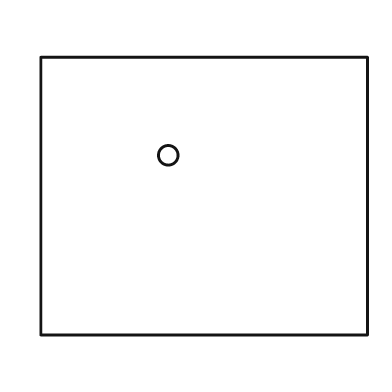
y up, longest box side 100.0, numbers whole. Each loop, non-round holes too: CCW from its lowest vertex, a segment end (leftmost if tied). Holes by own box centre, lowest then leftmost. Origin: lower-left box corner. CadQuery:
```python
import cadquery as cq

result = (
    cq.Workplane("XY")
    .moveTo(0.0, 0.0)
    .lineTo(100.0, 0.0)
    .lineTo(100.0, 85.0)
    .lineTo(0.0, 85.0)
    .close()
    .moveTo(39.0, 55.0)
    .circle(3.0)
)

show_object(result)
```